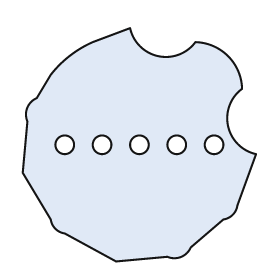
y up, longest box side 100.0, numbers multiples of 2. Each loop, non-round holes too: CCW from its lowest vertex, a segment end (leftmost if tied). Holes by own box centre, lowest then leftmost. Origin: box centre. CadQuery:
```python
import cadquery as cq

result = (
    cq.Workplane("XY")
    .moveTo(-10.0, -50.0)
    .lineTo(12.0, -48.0)
    .threePointArc((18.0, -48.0), (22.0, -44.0))
    .lineTo(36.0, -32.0)
    .threePointArc((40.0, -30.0), (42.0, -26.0))
    .lineTo(50.0, -4.0)
    .threePointArc((38.0, 8.0), (44.0, 24.0))
    .threePointArc((38.0, 38.0), (24.0, 44.0))
    .threePointArc((8.0, 38.0), (-4.0, 50.0))
    .lineTo(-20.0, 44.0)
    .threePointArc((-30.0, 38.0), (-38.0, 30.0))
    .lineTo(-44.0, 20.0)
    .threePointArc((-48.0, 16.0), (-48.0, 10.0))
    .lineTo(-50.0, -12.0)
    .lineTo(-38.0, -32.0)
    .threePointArc((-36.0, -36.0), (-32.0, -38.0))
    .close()
    .moveTo(-32.0, 0.0)
    .circle(4.0)
    .moveTo(-16.0, 0.0)
    .circle(4.0)
    .moveTo(0.0, 0.0)
    .circle(4.0)
    .moveTo(16.0, 0.0)
    .circle(4.0)
    .moveTo(32.0, 0.0)
    .circle(4.0)
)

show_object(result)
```